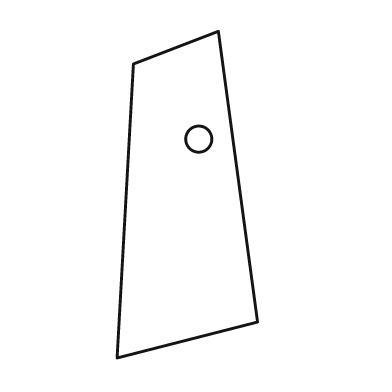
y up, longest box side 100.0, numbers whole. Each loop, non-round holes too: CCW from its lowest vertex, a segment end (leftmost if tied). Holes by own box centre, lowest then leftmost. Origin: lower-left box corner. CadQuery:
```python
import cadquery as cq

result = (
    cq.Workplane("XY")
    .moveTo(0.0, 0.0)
    .lineTo(43.0, 11.0)
    .lineTo(31.0, 100.0)
    .lineTo(5.0, 90.0)
    .close()
    .moveTo(25.0, 67.0)
    .circle(4.0)
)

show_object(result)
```